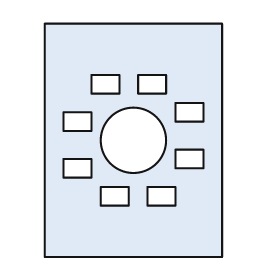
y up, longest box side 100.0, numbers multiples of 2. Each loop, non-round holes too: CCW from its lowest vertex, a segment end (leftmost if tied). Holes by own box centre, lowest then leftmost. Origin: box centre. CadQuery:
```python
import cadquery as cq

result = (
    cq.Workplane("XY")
    .moveTo(-38.0, -50.0)
    .lineTo(38.0, -50.0)
    .lineTo(38.0, 50.0)
    .lineTo(-38.0, 50.0)
    .close()
    .moveTo(-14.0, -28.0)
    .lineTo(-2.0, -28.0)
    .lineTo(-2.0, -20.0)
    .lineTo(-14.0, -20.0)
    .close()
    .moveTo(6.0, -28.0)
    .lineTo(18.0, -28.0)
    .lineTo(18.0, -20.0)
    .lineTo(6.0, -20.0)
    .close()
    .moveTo(-30.0, -16.0)
    .lineTo(-18.0, -16.0)
    .lineTo(-18.0, -8.0)
    .lineTo(-30.0, -8.0)
    .close()
    .moveTo(18.0, -12.0)
    .lineTo(30.0, -12.0)
    .lineTo(30.0, -4.0)
    .lineTo(18.0, -4.0)
    .close()
    .moveTo(0.0, 0.0)
    .circle(14.0)
    .moveTo(-30.0, 4.0)
    .lineTo(-18.0, 4.0)
    .lineTo(-18.0, 12.0)
    .lineTo(-30.0, 12.0)
    .close()
    .moveTo(18.0, 8.0)
    .lineTo(30.0, 8.0)
    .lineTo(30.0, 16.0)
    .lineTo(18.0, 16.0)
    .close()
    .moveTo(-18.0, 20.0)
    .lineTo(-6.0, 20.0)
    .lineTo(-6.0, 28.0)
    .lineTo(-18.0, 28.0)
    .close()
    .moveTo(2.0, 20.0)
    .lineTo(14.0, 20.0)
    .lineTo(14.0, 28.0)
    .lineTo(2.0, 28.0)
    .close()
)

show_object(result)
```